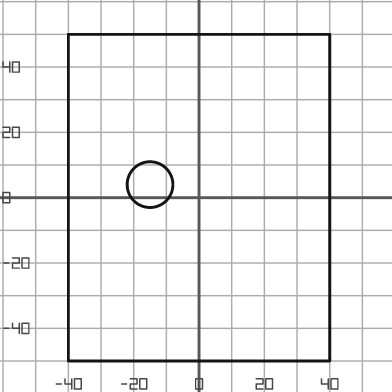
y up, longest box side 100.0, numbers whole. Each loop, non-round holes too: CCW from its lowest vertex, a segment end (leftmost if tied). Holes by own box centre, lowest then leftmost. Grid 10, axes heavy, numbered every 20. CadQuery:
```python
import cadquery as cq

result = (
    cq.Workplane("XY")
    .moveTo(-40.0, -50.0)
    .lineTo(40.0, -50.0)
    .lineTo(40.0, 50.0)
    .lineTo(-40.0, 50.0)
    .close()
    .moveTo(-15.0, 4.0)
    .circle(7.0)
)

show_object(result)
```